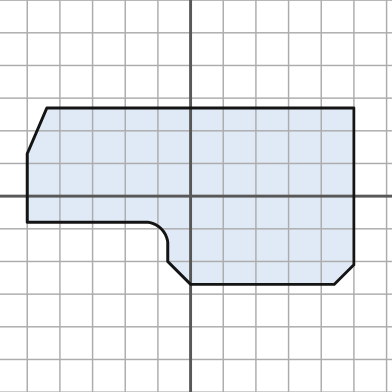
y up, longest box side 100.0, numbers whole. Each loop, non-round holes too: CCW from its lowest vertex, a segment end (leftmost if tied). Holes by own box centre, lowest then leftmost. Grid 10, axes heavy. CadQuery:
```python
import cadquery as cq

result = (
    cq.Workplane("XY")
    .moveTo(0.0, -27.0)
    .lineTo(44.0, -27.0)
    .lineTo(50.0, -21.0)
    .lineTo(50.0, 27.0)
    .lineTo(-44.0, 27.0)
    .lineTo(-50.0, 13.0)
    .lineTo(-50.0, -8.0)
    .lineTo(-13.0, -8.0)
    .threePointArc((-9.0, -10.0), (-7.0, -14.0))
    .lineTo(-7.0, -20.0)
    .close()
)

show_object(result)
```